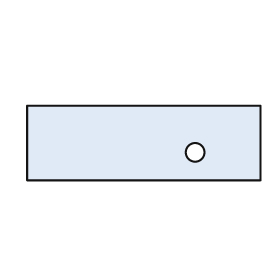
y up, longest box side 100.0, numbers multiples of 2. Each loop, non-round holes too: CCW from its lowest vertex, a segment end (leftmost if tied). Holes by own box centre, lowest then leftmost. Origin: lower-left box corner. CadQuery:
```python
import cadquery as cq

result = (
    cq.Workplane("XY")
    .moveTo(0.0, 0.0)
    .lineTo(100.0, 0.0)
    .lineTo(100.0, 32.0)
    .lineTo(0.0, 32.0)
    .close()
    .moveTo(72.0, 12.0)
    .circle(4.0)
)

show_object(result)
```